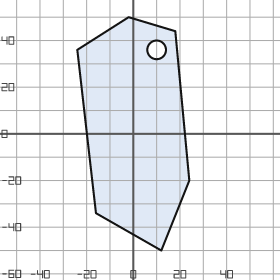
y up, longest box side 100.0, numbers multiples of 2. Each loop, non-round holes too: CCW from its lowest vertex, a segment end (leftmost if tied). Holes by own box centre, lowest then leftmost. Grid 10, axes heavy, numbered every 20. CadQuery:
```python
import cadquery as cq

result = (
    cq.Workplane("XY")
    .moveTo(12.0, -50.0)
    .lineTo(24.0, -20.0)
    .lineTo(18.0, 44.0)
    .lineTo(-2.0, 50.0)
    .lineTo(-24.0, 36.0)
    .lineTo(-16.0, -34.0)
    .close()
    .moveTo(10.0, 36.0)
    .circle(4.0)
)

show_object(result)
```